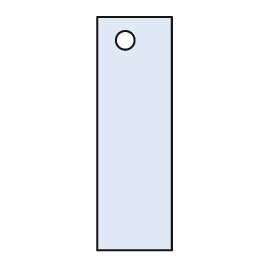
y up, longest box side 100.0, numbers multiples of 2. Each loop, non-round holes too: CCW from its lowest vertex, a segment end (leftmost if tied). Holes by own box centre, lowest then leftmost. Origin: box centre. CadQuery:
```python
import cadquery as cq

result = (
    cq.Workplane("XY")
    .moveTo(-16.0, -50.0)
    .lineTo(16.0, -50.0)
    .lineTo(16.0, 50.0)
    .lineTo(-16.0, 50.0)
    .close()
    .moveTo(-4.0, 40.0)
    .circle(4.0)
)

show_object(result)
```